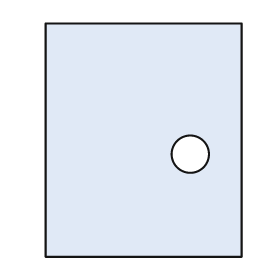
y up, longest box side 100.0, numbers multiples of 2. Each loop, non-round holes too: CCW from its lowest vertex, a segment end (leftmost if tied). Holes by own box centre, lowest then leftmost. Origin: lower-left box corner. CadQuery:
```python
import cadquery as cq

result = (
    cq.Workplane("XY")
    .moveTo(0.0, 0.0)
    .lineTo(84.0, 0.0)
    .lineTo(84.0, 100.0)
    .lineTo(0.0, 100.0)
    .close()
    .moveTo(62.0, 44.0)
    .circle(8.0)
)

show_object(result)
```